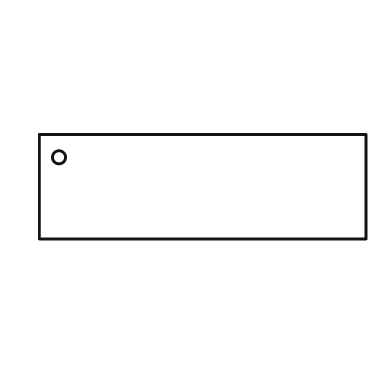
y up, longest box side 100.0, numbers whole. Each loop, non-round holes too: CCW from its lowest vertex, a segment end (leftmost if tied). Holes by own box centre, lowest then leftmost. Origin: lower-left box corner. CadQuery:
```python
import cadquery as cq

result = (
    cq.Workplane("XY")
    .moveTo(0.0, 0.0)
    .lineTo(100.0, 0.0)
    .lineTo(100.0, 32.0)
    .lineTo(0.0, 32.0)
    .close()
    .moveTo(6.0, 25.0)
    .circle(2.0)
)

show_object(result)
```